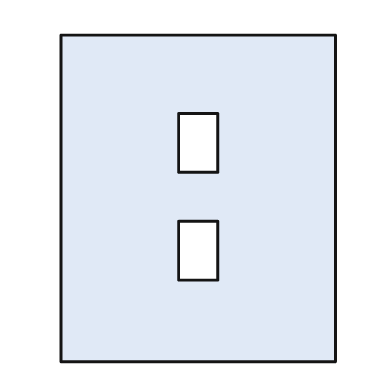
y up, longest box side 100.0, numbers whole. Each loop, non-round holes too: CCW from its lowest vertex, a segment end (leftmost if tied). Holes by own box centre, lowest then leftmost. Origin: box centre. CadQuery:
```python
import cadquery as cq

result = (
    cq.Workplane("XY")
    .moveTo(-42.0, -50.0)
    .lineTo(42.0, -50.0)
    .lineTo(42.0, 50.0)
    .lineTo(-42.0, 50.0)
    .close()
    .moveTo(-6.0, -25.0)
    .lineTo(6.0, -25.0)
    .lineTo(6.0, -7.0)
    .lineTo(-6.0, -7.0)
    .close()
    .moveTo(-6.0, 8.0)
    .lineTo(6.0, 8.0)
    .lineTo(6.0, 26.0)
    .lineTo(-6.0, 26.0)
    .close()
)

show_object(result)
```